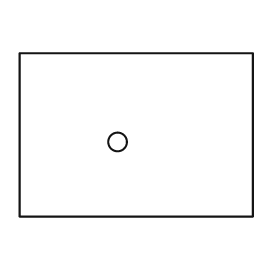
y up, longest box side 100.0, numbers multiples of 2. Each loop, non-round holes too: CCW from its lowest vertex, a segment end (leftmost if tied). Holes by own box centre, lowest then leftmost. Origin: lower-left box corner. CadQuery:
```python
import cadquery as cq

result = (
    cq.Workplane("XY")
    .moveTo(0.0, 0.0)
    .lineTo(100.0, 0.0)
    .lineTo(100.0, 70.0)
    .lineTo(0.0, 70.0)
    .close()
    .moveTo(42.0, 32.0)
    .circle(4.0)
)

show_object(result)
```